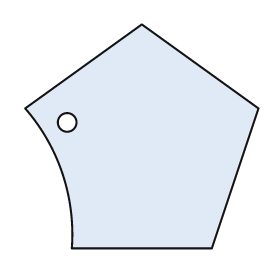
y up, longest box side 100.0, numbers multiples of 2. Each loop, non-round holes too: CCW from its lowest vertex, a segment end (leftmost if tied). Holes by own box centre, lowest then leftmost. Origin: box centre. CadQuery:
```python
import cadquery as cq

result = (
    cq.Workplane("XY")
    .moveTo(-30.0, -48.0)
    .lineTo(30.0, -48.0)
    .lineTo(50.0, 12.0)
    .lineTo(0.0, 48.0)
    .lineTo(-50.0, 12.0)
    .threePointArc((-34.0, -16.0), (-30.0, -48.0))
    .close()
    .moveTo(-32.0, 6.0)
    .circle(4.0)
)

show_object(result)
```